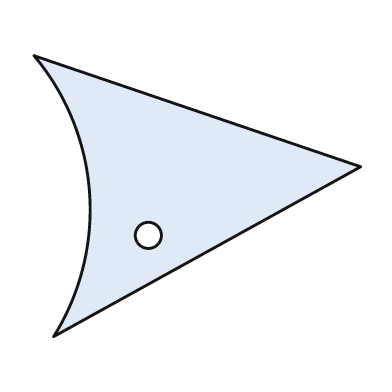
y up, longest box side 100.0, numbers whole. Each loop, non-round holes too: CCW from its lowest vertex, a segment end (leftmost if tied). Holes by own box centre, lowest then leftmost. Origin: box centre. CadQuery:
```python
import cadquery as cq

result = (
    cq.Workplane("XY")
    .moveTo(-44.0, -43.0)
    .lineTo(50.0, 9.0)
    .lineTo(-50.0, 43.0)
    .threePointArc((-33.0, 1.0), (-44.0, -43.0))
    .close()
    .moveTo(-15.0, -12.0)
    .circle(4.0)
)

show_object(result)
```